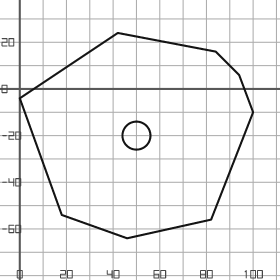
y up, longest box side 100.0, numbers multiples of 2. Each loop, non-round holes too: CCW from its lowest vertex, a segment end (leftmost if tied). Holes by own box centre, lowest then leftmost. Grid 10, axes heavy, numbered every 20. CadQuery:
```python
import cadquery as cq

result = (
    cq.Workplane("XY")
    .moveTo(46.0, -64.0)
    .lineTo(82.0, -56.0)
    .lineTo(100.0, -10.0)
    .lineTo(94.0, 6.0)
    .lineTo(84.0, 16.0)
    .lineTo(42.0, 24.0)
    .lineTo(0.0, -4.0)
    .lineTo(18.0, -54.0)
    .close()
    .moveTo(50.0, -20.0)
    .circle(6.0)
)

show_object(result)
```